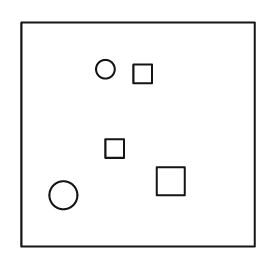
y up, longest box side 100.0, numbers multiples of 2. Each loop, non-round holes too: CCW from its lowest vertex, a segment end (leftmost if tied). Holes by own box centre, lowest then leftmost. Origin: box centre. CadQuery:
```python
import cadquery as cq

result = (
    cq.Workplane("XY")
    .moveTo(-50.0, -48.0)
    .lineTo(50.0, -48.0)
    .lineTo(50.0, 48.0)
    .lineTo(-50.0, 48.0)
    .close()
    .moveTo(-32.0, -26.0)
    .circle(6.0)
    .moveTo(8.0, -26.0)
    .lineTo(20.0, -26.0)
    .lineTo(20.0, -14.0)
    .lineTo(8.0, -14.0)
    .close()
    .moveTo(-14.0, -10.0)
    .lineTo(-6.0, -10.0)
    .lineTo(-6.0, -2.0)
    .lineTo(-14.0, -2.0)
    .close()
    .moveTo(-2.0, 22.0)
    .lineTo(6.0, 22.0)
    .lineTo(6.0, 30.0)
    .lineTo(-2.0, 30.0)
    .close()
    .moveTo(-14.0, 28.0)
    .circle(4.0)
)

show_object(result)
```